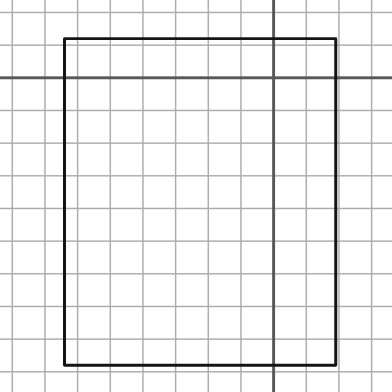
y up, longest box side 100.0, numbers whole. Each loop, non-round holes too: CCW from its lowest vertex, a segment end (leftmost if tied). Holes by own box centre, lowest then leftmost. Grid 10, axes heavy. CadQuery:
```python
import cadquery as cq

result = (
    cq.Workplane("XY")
    .moveTo(-64.0, -88.0)
    .lineTo(19.0, -88.0)
    .lineTo(19.0, 12.0)
    .lineTo(-64.0, 12.0)
    .close()
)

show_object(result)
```